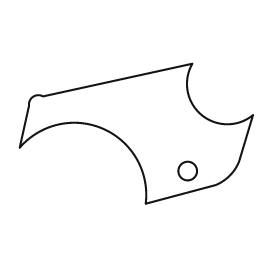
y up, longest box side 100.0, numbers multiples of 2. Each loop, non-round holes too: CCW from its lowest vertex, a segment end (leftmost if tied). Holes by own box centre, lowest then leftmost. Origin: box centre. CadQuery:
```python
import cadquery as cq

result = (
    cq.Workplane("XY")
    .moveTo(4.0, -30.0)
    .lineTo(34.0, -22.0)
    .threePointArc((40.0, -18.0), (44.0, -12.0))
    .lineTo(50.0, 8.0)
    .threePointArc((28.0, 8.0), (24.0, 30.0))
    .lineTo(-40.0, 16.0)
    .threePointArc((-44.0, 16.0), (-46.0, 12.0))
    .lineTo(-50.0, -6.0)
    .threePointArc((-14.0, 2.0), (4.0, -30.0))
    .close()
    .moveTo(22.0, -16.0)
    .circle(4.0)
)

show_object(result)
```